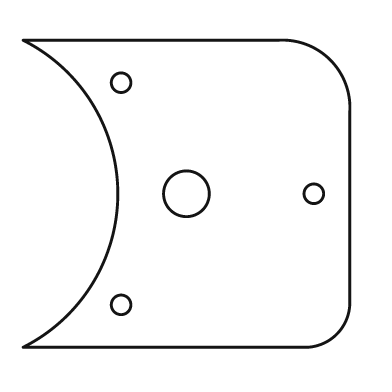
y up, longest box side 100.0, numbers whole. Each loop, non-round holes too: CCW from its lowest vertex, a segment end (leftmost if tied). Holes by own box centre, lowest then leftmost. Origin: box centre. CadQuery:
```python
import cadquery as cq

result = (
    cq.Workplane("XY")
    .moveTo(-50.0, -47.0)
    .lineTo(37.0, -47.0)
    .threePointArc((46.0, -43.0), (50.0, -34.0))
    .lineTo(50.0, 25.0)
    .threePointArc((44.0, 41.0), (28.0, 47.0))
    .lineTo(-50.0, 47.0)
    .threePointArc((-21.0, 0.0), (-50.0, -47.0))
    .close()
    .moveTo(-20.0, -34.0)
    .circle(3.0)
    .moveTo(0.0, 0.0)
    .circle(7.0)
    .moveTo(39.0, 0.0)
    .circle(3.0)
    .moveTo(-20.0, 34.0)
    .circle(3.0)
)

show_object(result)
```